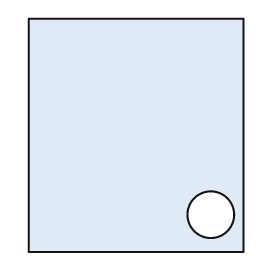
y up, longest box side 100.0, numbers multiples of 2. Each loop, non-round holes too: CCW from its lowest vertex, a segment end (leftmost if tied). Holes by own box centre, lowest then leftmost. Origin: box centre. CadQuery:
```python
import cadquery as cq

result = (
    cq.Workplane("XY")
    .moveTo(-46.0, -50.0)
    .lineTo(46.0, -50.0)
    .lineTo(46.0, 50.0)
    .lineTo(-46.0, 50.0)
    .close()
    .moveTo(32.0, -34.0)
    .circle(10.0)
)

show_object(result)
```